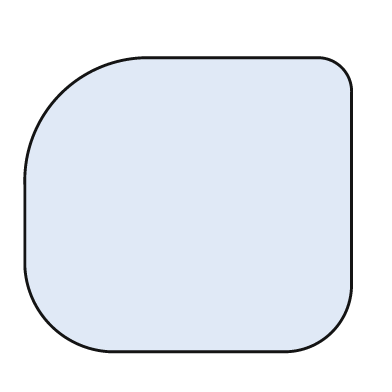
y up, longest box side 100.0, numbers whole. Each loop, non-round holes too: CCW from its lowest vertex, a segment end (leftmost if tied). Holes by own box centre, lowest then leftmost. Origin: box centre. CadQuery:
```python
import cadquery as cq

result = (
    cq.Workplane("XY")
    .moveTo(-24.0, -45.0)
    .lineTo(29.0, -45.0)
    .threePointArc((44.0, -39.0), (50.0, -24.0))
    .lineTo(50.0, 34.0)
    .threePointArc((47.0, 42.0), (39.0, 45.0))
    .lineTo(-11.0, 45.0)
    .threePointArc((-39.0, 34.0), (-50.0, 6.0))
    .lineTo(-50.0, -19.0)
    .threePointArc((-42.0, -37.0), (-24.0, -45.0))
    .close()
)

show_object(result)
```